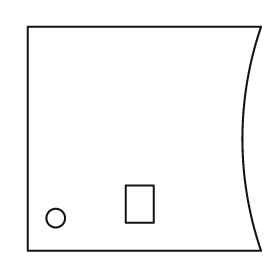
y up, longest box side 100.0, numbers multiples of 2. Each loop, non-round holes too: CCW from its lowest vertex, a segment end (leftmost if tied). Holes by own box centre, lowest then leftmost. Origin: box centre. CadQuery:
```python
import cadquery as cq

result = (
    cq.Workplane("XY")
    .moveTo(-50.0, -48.0)
    .lineTo(50.0, -48.0)
    .threePointArc((42.0, 0.0), (50.0, 48.0))
    .lineTo(-50.0, 48.0)
    .close()
    .moveTo(-38.0, -34.0)
    .circle(4.0)
    .moveTo(-8.0, -36.0)
    .lineTo(4.0, -36.0)
    .lineTo(4.0, -20.0)
    .lineTo(-8.0, -20.0)
    .close()
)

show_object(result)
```